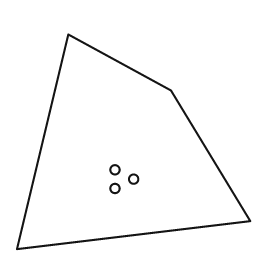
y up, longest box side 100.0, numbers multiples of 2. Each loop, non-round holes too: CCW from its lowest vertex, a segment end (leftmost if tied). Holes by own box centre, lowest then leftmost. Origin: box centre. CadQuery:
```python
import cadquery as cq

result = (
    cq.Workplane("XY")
    .moveTo(-50.0, -46.0)
    .lineTo(50.0, -34.0)
    .lineTo(16.0, 22.0)
    .lineTo(-28.0, 46.0)
    .close()
    .moveTo(-8.0, -20.0)
    .circle(2.0)
    .moveTo(0.0, -16.0)
    .circle(2.0)
    .moveTo(-8.0, -12.0)
    .circle(2.0)
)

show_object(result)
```